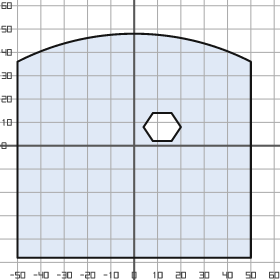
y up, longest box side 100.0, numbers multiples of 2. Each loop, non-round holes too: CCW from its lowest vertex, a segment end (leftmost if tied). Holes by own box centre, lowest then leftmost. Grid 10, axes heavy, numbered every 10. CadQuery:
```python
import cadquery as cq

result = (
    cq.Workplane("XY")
    .moveTo(-50.0, -48.0)
    .lineTo(50.0, -48.0)
    .lineTo(50.0, 36.0)
    .threePointArc((0.0, 48.0), (-50.0, 36.0))
    .close()
    .moveTo(8.0, 2.0)
    .lineTo(16.0, 2.0)
    .lineTo(20.0, 8.0)
    .lineTo(16.0, 14.0)
    .lineTo(8.0, 14.0)
    .lineTo(4.0, 8.0)
    .close()
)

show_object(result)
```